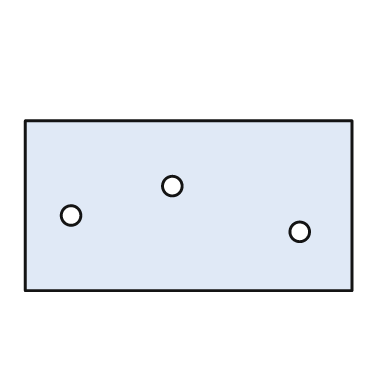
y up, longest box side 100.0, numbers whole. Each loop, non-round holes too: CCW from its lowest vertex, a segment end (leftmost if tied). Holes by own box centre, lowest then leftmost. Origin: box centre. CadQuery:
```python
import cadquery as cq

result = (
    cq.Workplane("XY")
    .moveTo(-50.0, -26.0)
    .lineTo(50.0, -26.0)
    .lineTo(50.0, 26.0)
    .lineTo(-50.0, 26.0)
    .close()
    .moveTo(34.0, -8.0)
    .circle(3.0)
    .moveTo(-36.0, -3.0)
    .circle(3.0)
    .moveTo(-5.0, 6.0)
    .circle(3.0)
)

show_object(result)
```